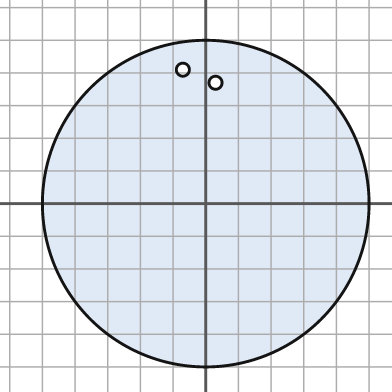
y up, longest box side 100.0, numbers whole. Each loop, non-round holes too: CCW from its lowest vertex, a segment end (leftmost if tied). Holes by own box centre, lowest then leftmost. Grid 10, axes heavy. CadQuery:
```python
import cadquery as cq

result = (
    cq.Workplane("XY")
    .moveTo(0.0, 0.0)
    .circle(50.0)
    .moveTo(3.0, 37.0)
    .circle(2.0)
    .moveTo(-7.0, 41.0)
    .circle(2.0)
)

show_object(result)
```